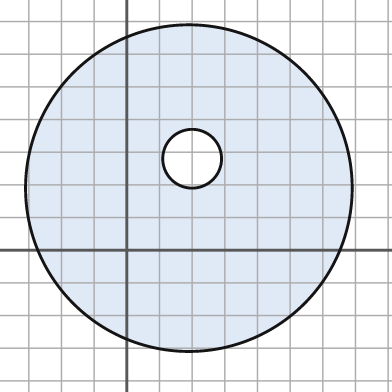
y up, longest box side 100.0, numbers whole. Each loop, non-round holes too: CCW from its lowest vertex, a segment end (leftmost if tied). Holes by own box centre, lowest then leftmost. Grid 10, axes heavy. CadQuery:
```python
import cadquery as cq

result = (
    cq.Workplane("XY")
    .moveTo(19.0, 19.0)
    .circle(50.0)
    .moveTo(20.0, 28.0)
    .circle(9.0)
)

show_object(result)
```